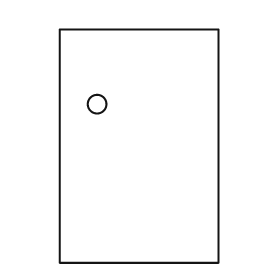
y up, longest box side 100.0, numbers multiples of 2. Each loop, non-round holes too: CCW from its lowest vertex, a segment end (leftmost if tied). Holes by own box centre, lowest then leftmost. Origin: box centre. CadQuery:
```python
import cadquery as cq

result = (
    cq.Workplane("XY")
    .moveTo(-34.0, -50.0)
    .lineTo(34.0, -50.0)
    .lineTo(34.0, 50.0)
    .lineTo(-34.0, 50.0)
    .close()
    .moveTo(-18.0, 18.0)
    .circle(4.0)
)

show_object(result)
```